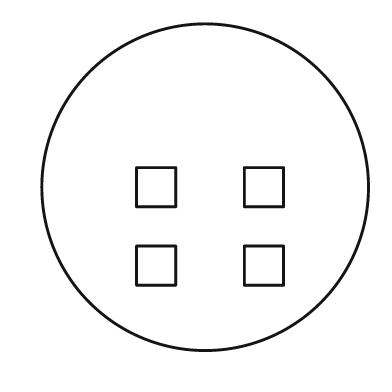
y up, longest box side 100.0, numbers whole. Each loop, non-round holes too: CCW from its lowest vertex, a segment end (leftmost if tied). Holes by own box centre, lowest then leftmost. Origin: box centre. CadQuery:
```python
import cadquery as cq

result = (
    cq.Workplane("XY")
    .moveTo(0.0, 0.0)
    .circle(50.0)
    .moveTo(-21.0, -30.0)
    .lineTo(-9.0, -30.0)
    .lineTo(-9.0, -18.0)
    .lineTo(-21.0, -18.0)
    .close()
    .moveTo(12.0, -30.0)
    .lineTo(24.0, -30.0)
    .lineTo(24.0, -18.0)
    .lineTo(12.0, -18.0)
    .close()
    .moveTo(-21.0, -6.0)
    .lineTo(-9.0, -6.0)
    .lineTo(-9.0, 6.0)
    .lineTo(-21.0, 6.0)
    .close()
    .moveTo(12.0, -6.0)
    .lineTo(24.0, -6.0)
    .lineTo(24.0, 6.0)
    .lineTo(12.0, 6.0)
    .close()
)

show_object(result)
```